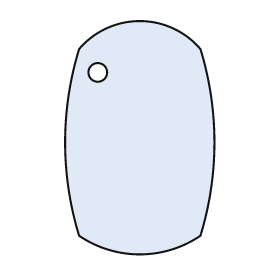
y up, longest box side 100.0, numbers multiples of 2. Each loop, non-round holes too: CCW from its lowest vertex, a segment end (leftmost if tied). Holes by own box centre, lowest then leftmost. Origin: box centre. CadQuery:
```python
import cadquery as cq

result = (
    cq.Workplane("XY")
    .moveTo(-26.0, -42.0)
    .threePointArc((0.0, -50.0), (26.0, -42.0))
    .threePointArc((32.0, -2.0), (26.0, 38.0))
    .threePointArc((0.0, 50.0), (-26.0, 38.0))
    .threePointArc((-32.0, -2.0), (-26.0, -42.0))
    .close()
    .moveTo(-18.0, 28.0)
    .circle(4.0)
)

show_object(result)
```